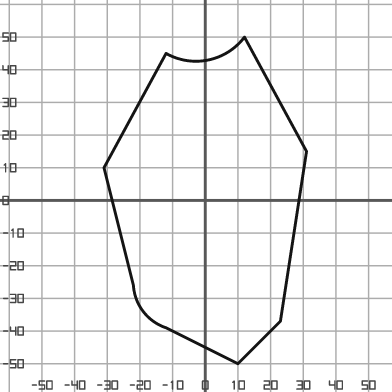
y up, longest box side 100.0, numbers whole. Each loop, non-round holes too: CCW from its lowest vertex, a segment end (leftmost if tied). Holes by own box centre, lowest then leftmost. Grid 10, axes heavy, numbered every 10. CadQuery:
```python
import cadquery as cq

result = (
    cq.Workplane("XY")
    .moveTo(10.0, -50.0)
    .lineTo(23.0, -37.0)
    .lineTo(31.0, 15.0)
    .lineTo(12.0, 50.0)
    .threePointArc((1.0, 43.0), (-12.0, 45.0))
    .lineTo(-31.0, 10.0)
    .lineTo(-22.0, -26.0)
    .threePointArc((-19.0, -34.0), (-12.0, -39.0))
    .close()
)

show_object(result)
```